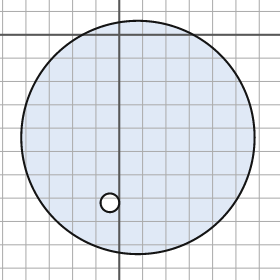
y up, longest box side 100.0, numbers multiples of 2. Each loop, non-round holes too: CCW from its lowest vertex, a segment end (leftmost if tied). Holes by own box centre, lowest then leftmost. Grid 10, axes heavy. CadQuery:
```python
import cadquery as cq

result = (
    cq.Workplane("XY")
    .moveTo(8.0, -44.0)
    .circle(50.0)
    .moveTo(-4.0, -72.0)
    .circle(4.0)
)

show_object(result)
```